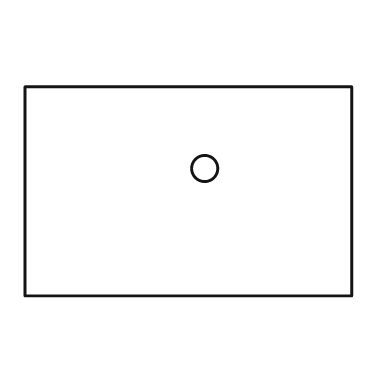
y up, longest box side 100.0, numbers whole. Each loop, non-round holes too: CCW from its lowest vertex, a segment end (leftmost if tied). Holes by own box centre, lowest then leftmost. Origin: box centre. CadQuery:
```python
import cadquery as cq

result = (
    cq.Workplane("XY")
    .moveTo(-50.0, -32.0)
    .lineTo(50.0, -32.0)
    .lineTo(50.0, 32.0)
    .lineTo(-50.0, 32.0)
    .close()
    .moveTo(5.0, 7.0)
    .circle(4.0)
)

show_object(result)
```